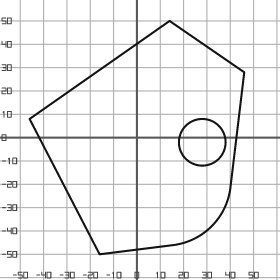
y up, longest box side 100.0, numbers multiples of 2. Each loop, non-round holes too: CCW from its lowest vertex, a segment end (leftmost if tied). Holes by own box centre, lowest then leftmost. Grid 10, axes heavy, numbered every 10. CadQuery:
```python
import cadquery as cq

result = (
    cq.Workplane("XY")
    .moveTo(-16.0, -50.0)
    .lineTo(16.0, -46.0)
    .threePointArc((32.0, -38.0), (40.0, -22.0))
    .lineTo(46.0, 28.0)
    .lineTo(14.0, 50.0)
    .lineTo(-46.0, 8.0)
    .close()
    .moveTo(28.0, -2.0)
    .circle(10.0)
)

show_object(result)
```